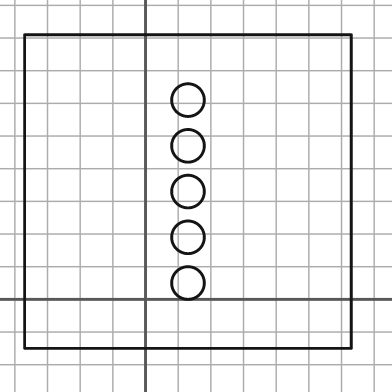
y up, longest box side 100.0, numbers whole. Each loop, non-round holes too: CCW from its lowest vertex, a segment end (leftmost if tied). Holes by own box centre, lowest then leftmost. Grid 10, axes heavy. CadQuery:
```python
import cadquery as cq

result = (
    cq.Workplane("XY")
    .moveTo(-37.0, -15.0)
    .lineTo(63.0, -15.0)
    .lineTo(63.0, 81.0)
    .lineTo(-37.0, 81.0)
    .close()
    .moveTo(13.0, 5.0)
    .circle(5.0)
    .moveTo(13.0, 19.0)
    .circle(5.0)
    .moveTo(13.0, 33.0)
    .circle(5.0)
    .moveTo(13.0, 47.0)
    .circle(5.0)
    .moveTo(13.0, 61.0)
    .circle(5.0)
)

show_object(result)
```